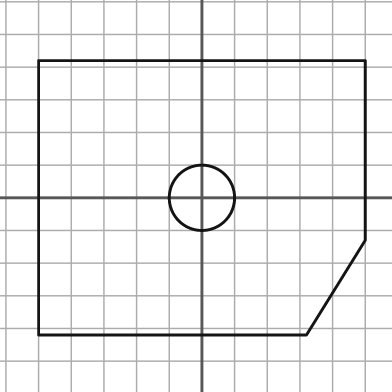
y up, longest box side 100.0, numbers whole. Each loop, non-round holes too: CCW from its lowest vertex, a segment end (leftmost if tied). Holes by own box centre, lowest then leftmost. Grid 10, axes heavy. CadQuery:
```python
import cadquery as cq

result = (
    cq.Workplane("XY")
    .moveTo(-50.0, -42.0)
    .lineTo(32.0, -42.0)
    .lineTo(50.0, -13.0)
    .lineTo(50.0, 42.0)
    .lineTo(-50.0, 42.0)
    .close()
    .moveTo(0.0, 0.0)
    .circle(10.0)
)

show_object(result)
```